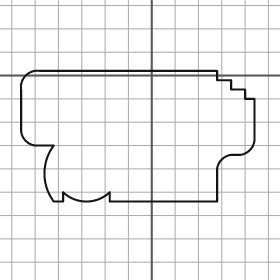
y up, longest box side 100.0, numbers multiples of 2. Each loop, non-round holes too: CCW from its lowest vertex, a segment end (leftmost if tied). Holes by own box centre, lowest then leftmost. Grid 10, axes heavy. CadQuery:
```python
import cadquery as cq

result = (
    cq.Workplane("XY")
    .moveTo(-42.0, -54.0)
    .lineTo(-38.0, -54.0)
    .lineTo(-38.0, -50.0)
    .threePointArc((-28.0, -54.0), (-18.0, -50.0))
    .lineTo(-18.0, -54.0)
    .lineTo(28.0, -54.0)
    .lineTo(28.0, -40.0)
    .threePointArc((30.0, -36.0), (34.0, -34.0))
    .lineTo(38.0, -34.0)
    .threePointArc((42.0, -32.0), (44.0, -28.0))
    .lineTo(44.0, -10.0)
    .lineTo(40.0, -10.0)
    .lineTo(40.0, -6.0)
    .lineTo(34.0, -6.0)
    .lineTo(34.0, -2.0)
    .lineTo(28.0, -2.0)
    .lineTo(28.0, 2.0)
    .lineTo(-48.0, 2.0)
    .threePointArc((-54.0, 0.0), (-56.0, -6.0))
    .lineTo(-56.0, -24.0)
    .threePointArc((-54.0, -28.0), (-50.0, -30.0))
    .lineTo(-42.0, -30.0)
    .threePointArc((-46.0, -42.0), (-42.0, -54.0))
    .close()
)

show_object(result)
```